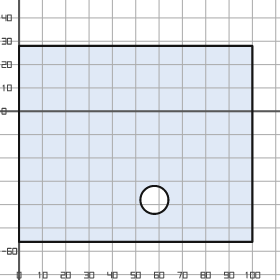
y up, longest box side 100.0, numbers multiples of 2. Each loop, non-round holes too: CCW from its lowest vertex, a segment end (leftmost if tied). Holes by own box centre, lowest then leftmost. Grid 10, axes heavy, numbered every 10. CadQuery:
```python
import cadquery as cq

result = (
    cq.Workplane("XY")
    .moveTo(0.0, -56.0)
    .lineTo(100.0, -56.0)
    .lineTo(100.0, 28.0)
    .lineTo(0.0, 28.0)
    .close()
    .moveTo(58.0, -38.0)
    .circle(6.0)
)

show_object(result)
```